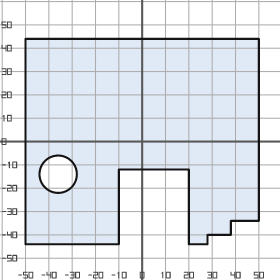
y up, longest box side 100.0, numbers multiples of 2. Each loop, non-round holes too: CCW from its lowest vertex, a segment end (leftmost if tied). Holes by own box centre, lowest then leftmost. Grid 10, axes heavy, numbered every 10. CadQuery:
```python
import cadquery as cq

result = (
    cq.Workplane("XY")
    .moveTo(-50.0, -44.0)
    .lineTo(-10.0, -44.0)
    .lineTo(-10.0, -12.0)
    .lineTo(20.0, -12.0)
    .lineTo(20.0, -44.0)
    .lineTo(28.0, -44.0)
    .lineTo(28.0, -40.0)
    .lineTo(38.0, -40.0)
    .lineTo(38.0, -34.0)
    .lineTo(50.0, -34.0)
    .lineTo(50.0, 44.0)
    .lineTo(-50.0, 44.0)
    .close()
    .moveTo(-36.0, -14.0)
    .circle(8.0)
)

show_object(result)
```